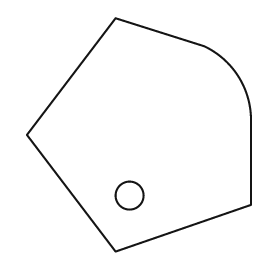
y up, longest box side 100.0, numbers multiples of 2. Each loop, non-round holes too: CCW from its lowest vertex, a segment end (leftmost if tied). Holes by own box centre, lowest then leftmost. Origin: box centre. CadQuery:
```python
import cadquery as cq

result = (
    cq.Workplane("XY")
    .moveTo(-10.0, -50.0)
    .lineTo(48.0, -30.0)
    .lineTo(48.0, 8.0)
    .threePointArc((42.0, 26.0), (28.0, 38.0))
    .lineTo(-10.0, 50.0)
    .lineTo(-48.0, 0.0)
    .close()
    .moveTo(-4.0, -26.0)
    .circle(6.0)
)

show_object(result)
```